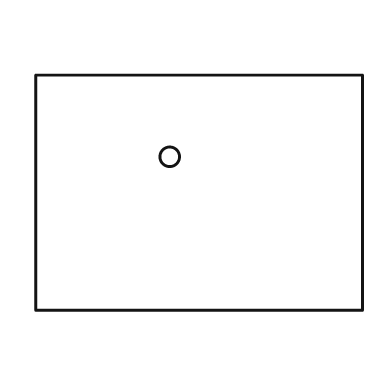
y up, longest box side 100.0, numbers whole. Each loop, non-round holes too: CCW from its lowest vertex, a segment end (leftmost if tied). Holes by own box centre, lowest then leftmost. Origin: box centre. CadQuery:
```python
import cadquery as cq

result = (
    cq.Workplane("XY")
    .moveTo(-50.0, -36.0)
    .lineTo(50.0, -36.0)
    .lineTo(50.0, 36.0)
    .lineTo(-50.0, 36.0)
    .close()
    .moveTo(-9.0, 11.0)
    .circle(3.0)
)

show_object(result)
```